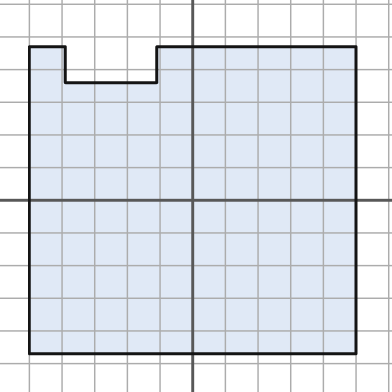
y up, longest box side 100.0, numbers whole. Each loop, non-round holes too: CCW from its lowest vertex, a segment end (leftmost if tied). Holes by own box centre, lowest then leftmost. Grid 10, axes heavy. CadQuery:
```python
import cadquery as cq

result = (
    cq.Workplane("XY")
    .moveTo(-50.0, -47.0)
    .lineTo(50.0, -47.0)
    .lineTo(50.0, 47.0)
    .lineTo(-11.0, 47.0)
    .lineTo(-11.0, 36.0)
    .lineTo(-39.0, 36.0)
    .lineTo(-39.0, 47.0)
    .lineTo(-50.0, 47.0)
    .close()
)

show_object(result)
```